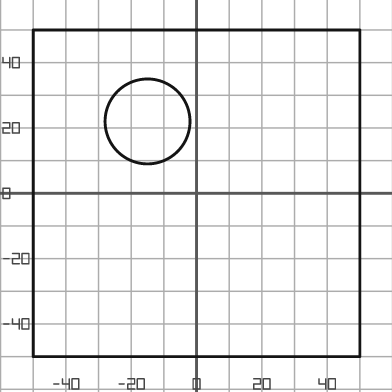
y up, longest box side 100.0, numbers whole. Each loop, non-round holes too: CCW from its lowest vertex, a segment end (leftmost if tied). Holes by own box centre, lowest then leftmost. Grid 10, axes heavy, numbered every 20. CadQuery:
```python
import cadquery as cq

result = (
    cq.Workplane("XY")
    .moveTo(-50.0, -50.0)
    .lineTo(50.0, -50.0)
    .lineTo(50.0, 50.0)
    .lineTo(-50.0, 50.0)
    .close()
    .moveTo(-15.0, 22.0)
    .circle(13.0)
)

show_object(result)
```